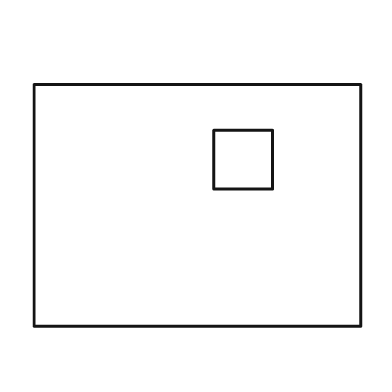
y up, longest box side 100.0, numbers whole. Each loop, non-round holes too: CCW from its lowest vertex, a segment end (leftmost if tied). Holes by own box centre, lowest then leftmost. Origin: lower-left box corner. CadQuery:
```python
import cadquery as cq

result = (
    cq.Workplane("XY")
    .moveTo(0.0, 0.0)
    .lineTo(100.0, 0.0)
    .lineTo(100.0, 74.0)
    .lineTo(0.0, 74.0)
    .close()
    .moveTo(55.0, 42.0)
    .lineTo(73.0, 42.0)
    .lineTo(73.0, 60.0)
    .lineTo(55.0, 60.0)
    .close()
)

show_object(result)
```